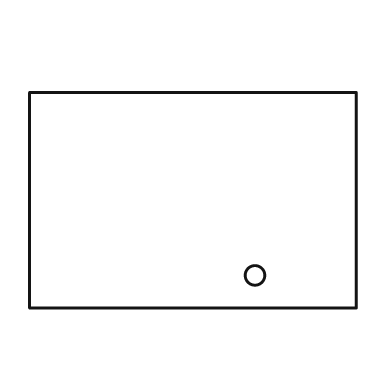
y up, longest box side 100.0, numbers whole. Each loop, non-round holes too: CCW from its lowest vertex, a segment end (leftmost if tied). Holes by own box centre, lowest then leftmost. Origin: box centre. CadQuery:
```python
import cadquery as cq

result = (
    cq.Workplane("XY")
    .moveTo(-50.0, -33.0)
    .lineTo(50.0, -33.0)
    .lineTo(50.0, 33.0)
    .lineTo(-50.0, 33.0)
    .close()
    .moveTo(19.0, -23.0)
    .circle(3.0)
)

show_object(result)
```